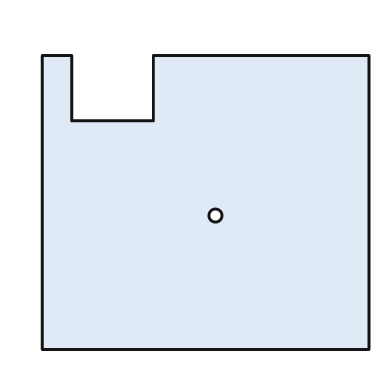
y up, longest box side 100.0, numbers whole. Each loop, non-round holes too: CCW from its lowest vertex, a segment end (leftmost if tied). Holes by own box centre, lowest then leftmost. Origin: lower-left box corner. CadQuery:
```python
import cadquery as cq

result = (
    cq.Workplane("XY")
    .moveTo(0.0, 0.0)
    .lineTo(100.0, 0.0)
    .lineTo(100.0, 90.0)
    .lineTo(34.0, 90.0)
    .lineTo(34.0, 70.0)
    .lineTo(9.0, 70.0)
    .lineTo(9.0, 90.0)
    .lineTo(0.0, 90.0)
    .close()
    .moveTo(53.0, 41.0)
    .circle(2.0)
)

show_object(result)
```